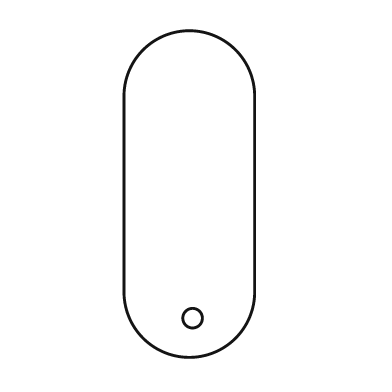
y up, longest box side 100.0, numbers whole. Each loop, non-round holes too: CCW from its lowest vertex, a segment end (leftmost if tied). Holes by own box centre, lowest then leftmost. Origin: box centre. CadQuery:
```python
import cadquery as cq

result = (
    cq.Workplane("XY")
    .moveTo(-20.0, -30.0)
    .threePointArc((0.0, -50.0), (20.0, -30.0))
    .lineTo(20.0, 30.0)
    .threePointArc((0.0, 50.0), (-20.0, 30.0))
    .close()
    .moveTo(1.0, -38.0)
    .circle(3.0)
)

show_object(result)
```